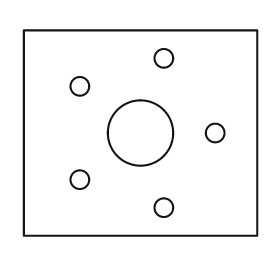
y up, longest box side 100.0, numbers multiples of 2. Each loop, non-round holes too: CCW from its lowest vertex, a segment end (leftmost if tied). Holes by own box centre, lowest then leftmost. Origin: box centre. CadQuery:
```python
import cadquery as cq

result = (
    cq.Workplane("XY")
    .moveTo(-50.0, -44.0)
    .lineTo(50.0, -44.0)
    .lineTo(50.0, 44.0)
    .lineTo(-50.0, 44.0)
    .close()
    .moveTo(10.0, -32.0)
    .circle(4.0)
    .moveTo(-26.0, -20.0)
    .circle(4.0)
    .moveTo(0.0, 0.0)
    .circle(14.0)
    .moveTo(32.0, 0.0)
    .circle(4.0)
    .moveTo(-26.0, 20.0)
    .circle(4.0)
    .moveTo(10.0, 32.0)
    .circle(4.0)
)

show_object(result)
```